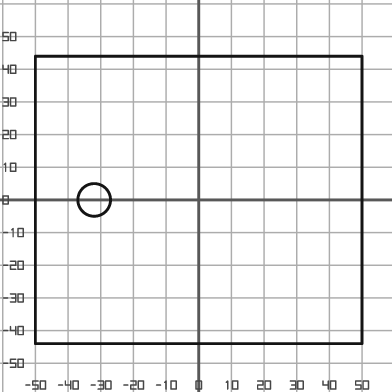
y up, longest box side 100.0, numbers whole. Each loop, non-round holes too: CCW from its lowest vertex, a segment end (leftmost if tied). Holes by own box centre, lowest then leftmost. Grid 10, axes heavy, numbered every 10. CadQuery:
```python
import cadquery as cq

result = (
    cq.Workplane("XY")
    .moveTo(-50.0, -44.0)
    .lineTo(50.0, -44.0)
    .lineTo(50.0, 44.0)
    .lineTo(-50.0, 44.0)
    .close()
    .moveTo(-32.0, 0.0)
    .circle(5.0)
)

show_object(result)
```